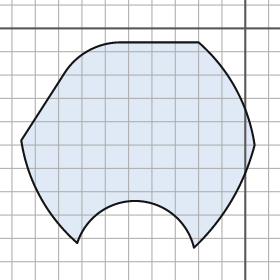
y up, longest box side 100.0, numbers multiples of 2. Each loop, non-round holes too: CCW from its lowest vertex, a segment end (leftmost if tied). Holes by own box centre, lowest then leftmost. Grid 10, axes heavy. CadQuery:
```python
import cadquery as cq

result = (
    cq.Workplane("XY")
    .moveTo(-22.0, -94.0)
    .threePointArc((-6.0, -74.0), (4.0, -50.0))
    .threePointArc((-4.0, -26.0), (-20.0, -6.0))
    .lineTo(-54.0, -6.0)
    .threePointArc((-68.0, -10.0), (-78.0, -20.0))
    .lineTo(-96.0, -48.0)
    .threePointArc((-88.0, -72.0), (-72.0, -92.0))
    .threePointArc((-46.0, -74.0), (-22.0, -94.0))
    .close()
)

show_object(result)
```